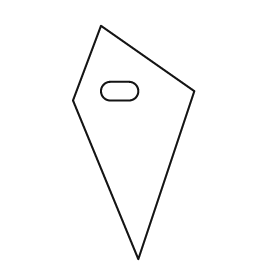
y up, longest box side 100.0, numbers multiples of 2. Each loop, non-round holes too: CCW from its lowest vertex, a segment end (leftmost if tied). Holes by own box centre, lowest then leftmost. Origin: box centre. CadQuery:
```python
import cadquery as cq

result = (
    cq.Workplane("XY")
    .moveTo(2.0, -50.0)
    .lineTo(26.0, 22.0)
    .lineTo(-14.0, 50.0)
    .lineTo(-26.0, 18.0)
    .close()
    .moveTo(-10.0, 18.0)
    .lineTo(-2.0, 18.0)
    .threePointArc((2.0, 22.0), (-2.0, 26.0))
    .lineTo(-10.0, 26.0)
    .threePointArc((-14.0, 22.0), (-10.0, 18.0))
    .close()
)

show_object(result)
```